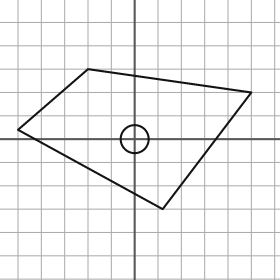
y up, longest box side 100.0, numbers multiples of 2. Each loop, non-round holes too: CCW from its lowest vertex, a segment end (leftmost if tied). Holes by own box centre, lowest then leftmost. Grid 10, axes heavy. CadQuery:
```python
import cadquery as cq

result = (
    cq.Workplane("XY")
    .moveTo(12.0, -30.0)
    .lineTo(50.0, 20.0)
    .lineTo(-20.0, 30.0)
    .lineTo(-50.0, 4.0)
    .close()
    .moveTo(0.0, 0.0)
    .circle(6.0)
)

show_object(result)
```